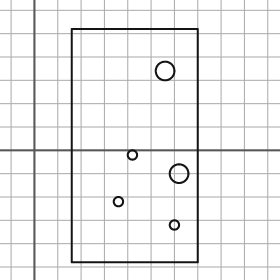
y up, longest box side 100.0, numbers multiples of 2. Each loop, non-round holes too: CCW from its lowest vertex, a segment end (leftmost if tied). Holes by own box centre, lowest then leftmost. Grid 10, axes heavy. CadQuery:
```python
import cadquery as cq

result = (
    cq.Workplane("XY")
    .moveTo(16.0, -48.0)
    .lineTo(70.0, -48.0)
    .lineTo(70.0, 52.0)
    .lineTo(16.0, 52.0)
    .close()
    .moveTo(60.0, -32.0)
    .circle(2.0)
    .moveTo(36.0, -22.0)
    .circle(2.0)
    .moveTo(62.0, -10.0)
    .circle(4.0)
    .moveTo(42.0, -2.0)
    .circle(2.0)
    .moveTo(56.0, 34.0)
    .circle(4.0)
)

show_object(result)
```